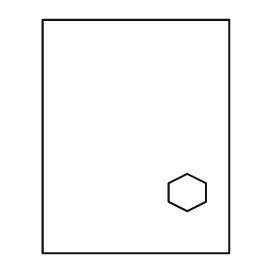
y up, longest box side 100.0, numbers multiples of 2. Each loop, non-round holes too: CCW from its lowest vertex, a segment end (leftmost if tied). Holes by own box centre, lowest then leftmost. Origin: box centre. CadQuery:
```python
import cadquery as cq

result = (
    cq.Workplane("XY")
    .moveTo(-40.0, -50.0)
    .lineTo(40.0, -50.0)
    .lineTo(40.0, 50.0)
    .lineTo(-40.0, 50.0)
    .close()
    .moveTo(22.0, -32.0)
    .lineTo(30.0, -28.0)
    .lineTo(30.0, -20.0)
    .lineTo(22.0, -16.0)
    .lineTo(14.0, -20.0)
    .lineTo(14.0, -28.0)
    .close()
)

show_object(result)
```